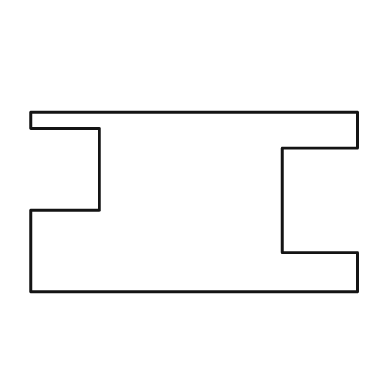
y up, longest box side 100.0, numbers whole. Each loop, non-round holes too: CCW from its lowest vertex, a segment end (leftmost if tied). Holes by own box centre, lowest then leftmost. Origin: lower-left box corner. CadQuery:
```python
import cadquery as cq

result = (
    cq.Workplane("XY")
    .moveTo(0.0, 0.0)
    .lineTo(100.0, 0.0)
    .lineTo(100.0, 12.0)
    .lineTo(77.0, 12.0)
    .lineTo(77.0, 44.0)
    .lineTo(100.0, 44.0)
    .lineTo(100.0, 55.0)
    .lineTo(0.0, 55.0)
    .lineTo(0.0, 50.0)
    .lineTo(21.0, 50.0)
    .lineTo(21.0, 25.0)
    .lineTo(0.0, 25.0)
    .close()
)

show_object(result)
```